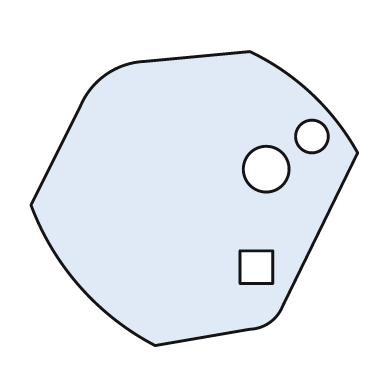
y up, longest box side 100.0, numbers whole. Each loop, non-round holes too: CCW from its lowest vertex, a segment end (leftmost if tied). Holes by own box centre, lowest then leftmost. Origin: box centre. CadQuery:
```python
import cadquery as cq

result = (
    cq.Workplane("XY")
    .moveTo(-12.0, -45.0)
    .lineTo(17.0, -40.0)
    .threePointArc((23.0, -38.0), (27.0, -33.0))
    .lineTo(50.0, 14.0)
    .threePointArc((36.0, 32.0), (17.0, 45.0))
    .lineTo(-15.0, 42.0)
    .threePointArc((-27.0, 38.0), (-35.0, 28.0))
    .lineTo(-50.0, -2.0)
    .threePointArc((-35.0, -27.0), (-12.0, -45.0))
    .close()
    .moveTo(14.0, -26.0)
    .lineTo(24.0, -26.0)
    .lineTo(24.0, -16.0)
    .lineTo(14.0, -16.0)
    .close()
    .moveTo(22.0, 9.0)
    .circle(7.0)
    .moveTo(36.0, 19.0)
    .circle(5.0)
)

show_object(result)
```